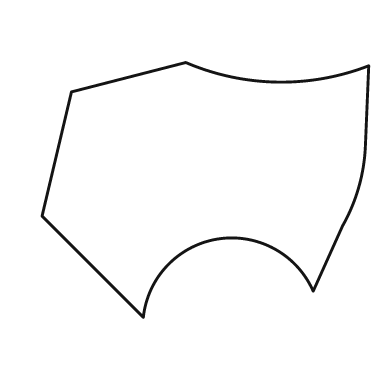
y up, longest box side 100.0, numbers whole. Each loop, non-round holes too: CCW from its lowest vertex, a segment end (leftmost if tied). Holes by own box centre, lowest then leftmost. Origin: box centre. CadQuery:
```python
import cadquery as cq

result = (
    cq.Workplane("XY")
    .moveTo(-19.0, -39.0)
    .threePointArc((4.0, -15.0), (33.0, -31.0))
    .lineTo(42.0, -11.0)
    .threePointArc((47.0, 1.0), (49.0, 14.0))
    .lineTo(50.0, 38.0)
    .threePointArc((22.0, 33.0), (-6.0, 39.0))
    .lineTo(-41.0, 30.0)
    .lineTo(-50.0, -8.0)
    .close()
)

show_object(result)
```